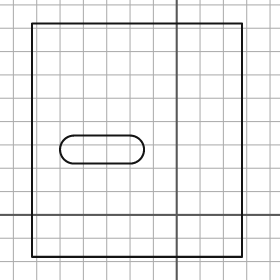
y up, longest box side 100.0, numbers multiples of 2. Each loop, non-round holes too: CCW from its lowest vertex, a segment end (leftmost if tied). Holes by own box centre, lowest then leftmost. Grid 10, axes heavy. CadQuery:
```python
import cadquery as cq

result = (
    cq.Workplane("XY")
    .moveTo(-62.0, -18.0)
    .lineTo(28.0, -18.0)
    .lineTo(28.0, 82.0)
    .lineTo(-62.0, 82.0)
    .close()
    .moveTo(-44.0, 22.0)
    .lineTo(-20.0, 22.0)
    .threePointArc((-14.0, 28.0), (-20.0, 34.0))
    .lineTo(-44.0, 34.0)
    .threePointArc((-50.0, 28.0), (-44.0, 22.0))
    .close()
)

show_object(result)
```